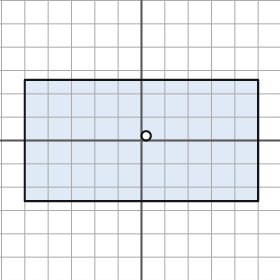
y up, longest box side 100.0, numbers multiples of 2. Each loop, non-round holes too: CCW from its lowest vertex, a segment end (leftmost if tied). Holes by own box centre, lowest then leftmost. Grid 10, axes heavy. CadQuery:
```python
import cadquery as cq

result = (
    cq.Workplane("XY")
    .moveTo(-50.0, -26.0)
    .lineTo(50.0, -26.0)
    .lineTo(50.0, 26.0)
    .lineTo(-50.0, 26.0)
    .close()
    .moveTo(2.0, 2.0)
    .circle(2.0)
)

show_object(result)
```